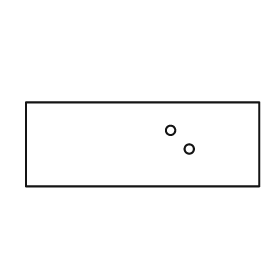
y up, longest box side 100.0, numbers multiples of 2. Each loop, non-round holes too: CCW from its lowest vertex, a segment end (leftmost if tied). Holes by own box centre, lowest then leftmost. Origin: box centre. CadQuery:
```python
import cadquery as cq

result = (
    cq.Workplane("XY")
    .moveTo(-50.0, -18.0)
    .lineTo(50.0, -18.0)
    .lineTo(50.0, 18.0)
    .lineTo(-50.0, 18.0)
    .close()
    .moveTo(20.0, -2.0)
    .circle(2.0)
    .moveTo(12.0, 6.0)
    .circle(2.0)
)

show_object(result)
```